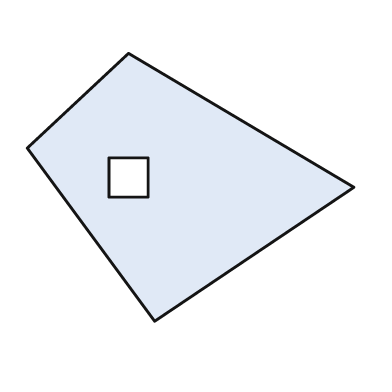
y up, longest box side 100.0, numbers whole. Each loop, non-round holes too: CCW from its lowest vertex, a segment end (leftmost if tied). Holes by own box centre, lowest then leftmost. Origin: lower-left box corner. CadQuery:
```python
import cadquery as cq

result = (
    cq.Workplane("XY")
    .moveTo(39.0, 0.0)
    .lineTo(100.0, 41.0)
    .lineTo(31.0, 82.0)
    .lineTo(0.0, 53.0)
    .close()
    .moveTo(25.0, 38.0)
    .lineTo(37.0, 38.0)
    .lineTo(37.0, 50.0)
    .lineTo(25.0, 50.0)
    .close()
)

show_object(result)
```